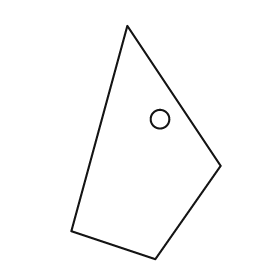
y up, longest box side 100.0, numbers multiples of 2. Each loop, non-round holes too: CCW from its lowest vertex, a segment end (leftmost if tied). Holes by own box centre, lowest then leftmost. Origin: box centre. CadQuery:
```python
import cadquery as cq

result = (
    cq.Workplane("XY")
    .moveTo(4.0, -50.0)
    .lineTo(32.0, -10.0)
    .lineTo(-8.0, 50.0)
    .lineTo(-32.0, -38.0)
    .close()
    .moveTo(6.0, 10.0)
    .circle(4.0)
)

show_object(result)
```